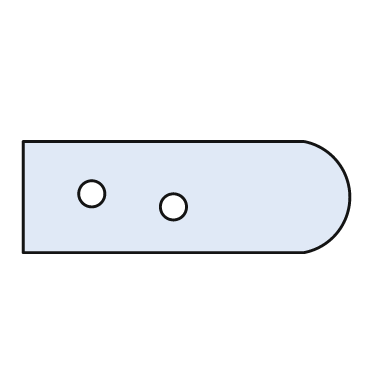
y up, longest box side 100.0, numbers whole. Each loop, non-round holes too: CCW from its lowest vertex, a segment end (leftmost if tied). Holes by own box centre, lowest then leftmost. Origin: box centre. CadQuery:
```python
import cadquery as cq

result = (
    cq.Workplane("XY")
    .moveTo(-50.0, -17.0)
    .lineTo(36.0, -17.0)
    .threePointArc((50.0, 0.0), (36.0, 17.0))
    .lineTo(-50.0, 17.0)
    .close()
    .moveTo(-4.0, -3.0)
    .circle(4.0)
    .moveTo(-29.0, 1.0)
    .circle(4.0)
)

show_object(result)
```